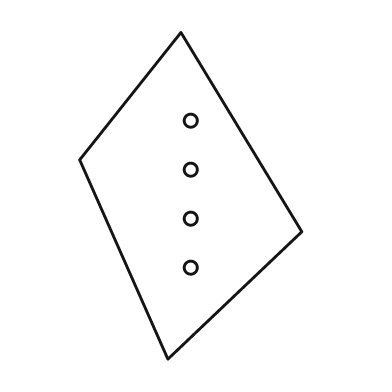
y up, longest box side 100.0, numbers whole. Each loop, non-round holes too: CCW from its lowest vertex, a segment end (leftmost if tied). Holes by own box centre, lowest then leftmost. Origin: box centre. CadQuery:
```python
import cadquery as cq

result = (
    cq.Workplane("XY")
    .moveTo(-7.0, -50.0)
    .lineTo(34.0, -11.0)
    .lineTo(-3.0, 50.0)
    .lineTo(-34.0, 11.0)
    .close()
    .moveTo(0.0, -22.0)
    .circle(2.0)
    .moveTo(0.0, -7.0)
    .circle(2.0)
    .moveTo(0.0, 8.0)
    .circle(2.0)
    .moveTo(0.0, 23.0)
    .circle(2.0)
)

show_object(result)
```